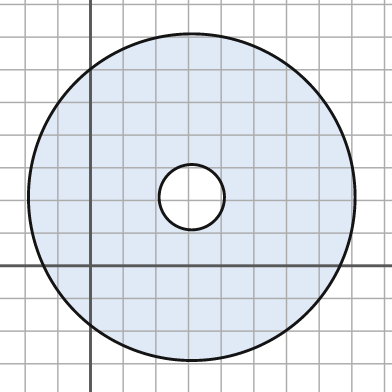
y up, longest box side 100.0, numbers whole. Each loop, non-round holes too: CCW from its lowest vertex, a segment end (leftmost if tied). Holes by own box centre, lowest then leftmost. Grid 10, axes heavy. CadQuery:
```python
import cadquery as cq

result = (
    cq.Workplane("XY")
    .moveTo(31.0, 21.0)
    .circle(50.0)
    .moveTo(31.0, 21.0)
    .circle(10.0)
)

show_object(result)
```